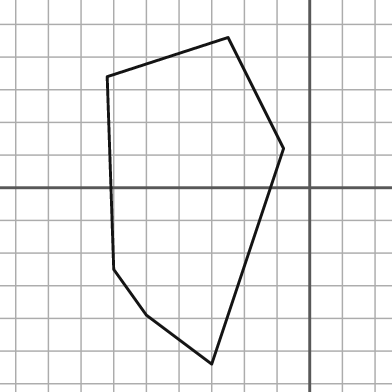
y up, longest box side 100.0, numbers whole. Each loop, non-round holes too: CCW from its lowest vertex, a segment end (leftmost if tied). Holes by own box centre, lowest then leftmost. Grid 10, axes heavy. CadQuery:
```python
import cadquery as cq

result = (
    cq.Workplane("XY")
    .moveTo(-30.0, -54.0)
    .lineTo(-8.0, 12.0)
    .lineTo(-25.0, 46.0)
    .lineTo(-62.0, 34.0)
    .lineTo(-60.0, -25.0)
    .lineTo(-50.0, -39.0)
    .close()
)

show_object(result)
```